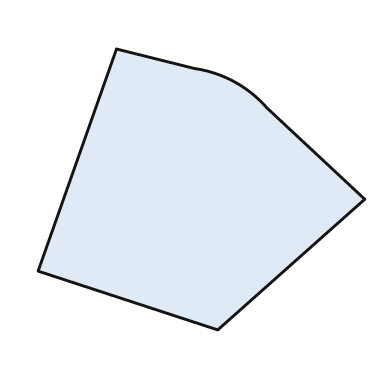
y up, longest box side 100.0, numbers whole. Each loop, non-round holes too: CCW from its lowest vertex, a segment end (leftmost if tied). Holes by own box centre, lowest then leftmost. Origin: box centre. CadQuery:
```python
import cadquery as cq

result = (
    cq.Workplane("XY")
    .moveTo(5.0, -43.0)
    .lineTo(50.0, -3.0)
    .lineTo(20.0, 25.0)
    .threePointArc((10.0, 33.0), (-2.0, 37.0))
    .lineTo(-26.0, 43.0)
    .lineTo(-50.0, -25.0)
    .close()
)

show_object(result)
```